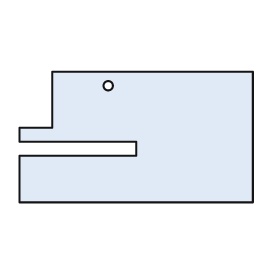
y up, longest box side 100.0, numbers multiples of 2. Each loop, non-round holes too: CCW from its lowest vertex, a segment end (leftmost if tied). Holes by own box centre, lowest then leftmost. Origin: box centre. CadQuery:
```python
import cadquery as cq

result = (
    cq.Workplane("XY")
    .moveTo(-50.0, -28.0)
    .lineTo(50.0, -28.0)
    .lineTo(50.0, 28.0)
    .lineTo(-36.0, 28.0)
    .lineTo(-36.0, 4.0)
    .lineTo(-50.0, 4.0)
    .lineTo(-50.0, -2.0)
    .lineTo(0.0, -2.0)
    .lineTo(0.0, -8.0)
    .lineTo(-50.0, -8.0)
    .close()
    .moveTo(-12.0, 22.0)
    .circle(2.0)
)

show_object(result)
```